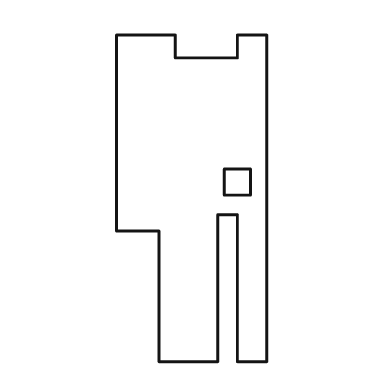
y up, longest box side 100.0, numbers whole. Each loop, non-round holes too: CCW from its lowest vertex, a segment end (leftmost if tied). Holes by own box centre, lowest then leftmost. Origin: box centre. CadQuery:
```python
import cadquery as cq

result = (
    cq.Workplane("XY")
    .moveTo(-10.0, -50.0)
    .lineTo(8.0, -50.0)
    .lineTo(8.0, -5.0)
    .lineTo(14.0, -5.0)
    .lineTo(14.0, -50.0)
    .lineTo(23.0, -50.0)
    .lineTo(23.0, 50.0)
    .lineTo(14.0, 50.0)
    .lineTo(14.0, 43.0)
    .lineTo(-5.0, 43.0)
    .lineTo(-5.0, 50.0)
    .lineTo(-23.0, 50.0)
    .lineTo(-23.0, -10.0)
    .lineTo(-10.0, -10.0)
    .close()
    .moveTo(10.0, 1.0)
    .lineTo(18.0, 1.0)
    .lineTo(18.0, 9.0)
    .lineTo(10.0, 9.0)
    .close()
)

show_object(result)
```